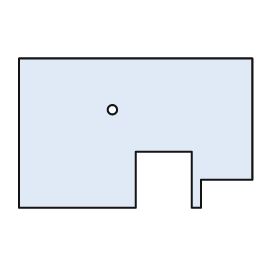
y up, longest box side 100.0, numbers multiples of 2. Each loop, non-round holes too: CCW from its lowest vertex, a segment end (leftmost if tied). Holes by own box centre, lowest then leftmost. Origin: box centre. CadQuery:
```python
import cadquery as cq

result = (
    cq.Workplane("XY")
    .moveTo(-50.0, -32.0)
    .lineTo(0.0, -32.0)
    .lineTo(0.0, -8.0)
    .lineTo(24.0, -8.0)
    .lineTo(24.0, -32.0)
    .lineTo(28.0, -32.0)
    .lineTo(28.0, -20.0)
    .lineTo(50.0, -20.0)
    .lineTo(50.0, 32.0)
    .lineTo(-50.0, 32.0)
    .close()
    .moveTo(-10.0, 10.0)
    .circle(2.0)
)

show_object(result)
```